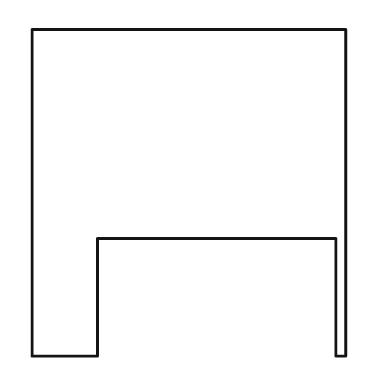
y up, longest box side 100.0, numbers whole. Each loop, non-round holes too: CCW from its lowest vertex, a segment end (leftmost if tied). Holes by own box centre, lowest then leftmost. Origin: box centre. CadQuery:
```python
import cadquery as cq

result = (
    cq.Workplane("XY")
    .moveTo(-48.0, -50.0)
    .lineTo(-28.0, -50.0)
    .lineTo(-28.0, -14.0)
    .lineTo(45.0, -14.0)
    .lineTo(45.0, -50.0)
    .lineTo(48.0, -50.0)
    .lineTo(48.0, 50.0)
    .lineTo(-48.0, 50.0)
    .close()
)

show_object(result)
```